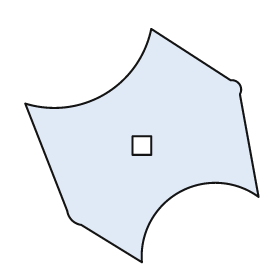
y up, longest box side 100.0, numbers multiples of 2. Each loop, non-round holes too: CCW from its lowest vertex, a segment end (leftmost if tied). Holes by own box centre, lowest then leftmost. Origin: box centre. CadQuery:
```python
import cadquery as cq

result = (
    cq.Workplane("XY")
    .moveTo(0.0, -50.0)
    .threePointArc((16.0, -20.0), (50.0, -22.0))
    .lineTo(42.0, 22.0)
    .threePointArc((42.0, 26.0), (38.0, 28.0))
    .lineTo(4.0, 50.0)
    .threePointArc((-16.0, 22.0), (-50.0, 18.0))
    .lineTo(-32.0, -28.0)
    .threePointArc((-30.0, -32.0), (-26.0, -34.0))
    .close()
    .moveTo(-4.0, -4.0)
    .lineTo(4.0, -4.0)
    .lineTo(4.0, 4.0)
    .lineTo(-4.0, 4.0)
    .close()
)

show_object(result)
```